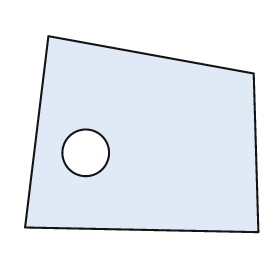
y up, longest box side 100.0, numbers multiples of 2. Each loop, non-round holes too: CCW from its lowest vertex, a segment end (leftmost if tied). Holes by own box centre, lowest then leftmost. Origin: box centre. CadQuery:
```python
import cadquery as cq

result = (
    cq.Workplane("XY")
    .moveTo(50.0, -42.0)
    .lineTo(48.0, 26.0)
    .lineTo(-40.0, 42.0)
    .lineTo(-50.0, -40.0)
    .close()
    .moveTo(-24.0, -8.0)
    .circle(10.0)
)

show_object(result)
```